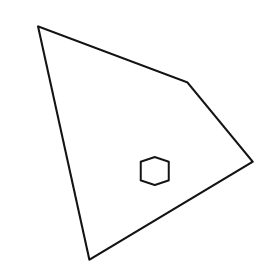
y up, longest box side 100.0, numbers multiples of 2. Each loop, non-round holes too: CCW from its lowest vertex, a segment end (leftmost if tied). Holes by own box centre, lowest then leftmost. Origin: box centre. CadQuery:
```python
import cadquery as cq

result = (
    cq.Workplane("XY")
    .moveTo(-24.0, -50.0)
    .lineTo(46.0, -8.0)
    .lineTo(18.0, 26.0)
    .lineTo(-46.0, 50.0)
    .close()
    .moveTo(4.0, -18.0)
    .lineTo(10.0, -16.0)
    .lineTo(10.0, -8.0)
    .lineTo(4.0, -6.0)
    .lineTo(-2.0, -8.0)
    .lineTo(-2.0, -16.0)
    .close()
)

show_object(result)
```